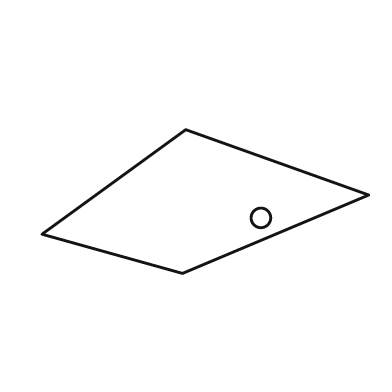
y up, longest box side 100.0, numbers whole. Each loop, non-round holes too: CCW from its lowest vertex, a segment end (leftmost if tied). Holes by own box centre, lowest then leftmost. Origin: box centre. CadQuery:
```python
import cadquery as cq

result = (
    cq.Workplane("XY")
    .moveTo(-7.0, -22.0)
    .lineTo(50.0, 2.0)
    .lineTo(-6.0, 22.0)
    .lineTo(-50.0, -10.0)
    .close()
    .moveTo(17.0, -5.0)
    .circle(3.0)
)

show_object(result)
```